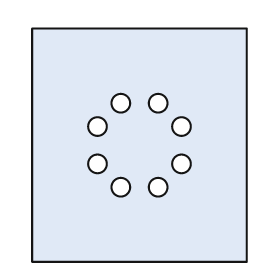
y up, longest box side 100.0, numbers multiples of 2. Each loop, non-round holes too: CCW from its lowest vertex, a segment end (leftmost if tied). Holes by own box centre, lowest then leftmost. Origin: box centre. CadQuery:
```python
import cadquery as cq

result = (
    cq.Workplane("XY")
    .moveTo(-46.0, -50.0)
    .lineTo(46.0, -50.0)
    .lineTo(46.0, 50.0)
    .lineTo(-46.0, 50.0)
    .close()
    .moveTo(-8.0, -18.0)
    .circle(4.0)
    .moveTo(8.0, -18.0)
    .circle(4.0)
    .moveTo(-18.0, -8.0)
    .circle(4.0)
    .moveTo(18.0, -8.0)
    .circle(4.0)
    .moveTo(-18.0, 8.0)
    .circle(4.0)
    .moveTo(18.0, 8.0)
    .circle(4.0)
    .moveTo(-8.0, 18.0)
    .circle(4.0)
    .moveTo(8.0, 18.0)
    .circle(4.0)
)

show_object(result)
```